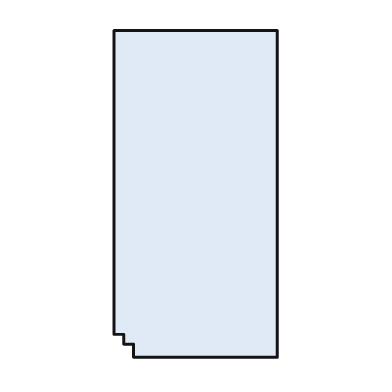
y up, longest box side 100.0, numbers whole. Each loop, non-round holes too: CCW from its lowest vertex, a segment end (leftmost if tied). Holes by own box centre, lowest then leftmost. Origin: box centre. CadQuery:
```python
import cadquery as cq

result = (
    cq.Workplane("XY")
    .moveTo(-19.0, -50.0)
    .lineTo(25.0, -50.0)
    .lineTo(25.0, 50.0)
    .lineTo(-25.0, 50.0)
    .lineTo(-25.0, -43.0)
    .lineTo(-22.0, -43.0)
    .lineTo(-22.0, -46.0)
    .lineTo(-19.0, -46.0)
    .close()
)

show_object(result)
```